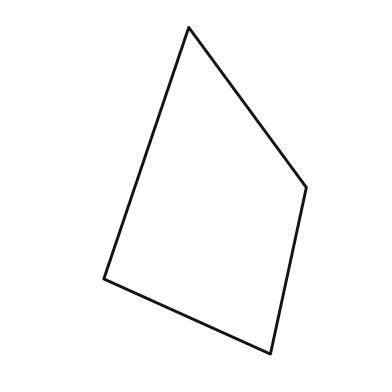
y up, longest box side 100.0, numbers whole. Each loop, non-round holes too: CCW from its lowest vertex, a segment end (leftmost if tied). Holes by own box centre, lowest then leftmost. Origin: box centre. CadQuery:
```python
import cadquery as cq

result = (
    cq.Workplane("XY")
    .moveTo(20.0, -50.0)
    .lineTo(31.0, 1.0)
    .lineTo(-5.0, 50.0)
    .lineTo(-31.0, -27.0)
    .close()
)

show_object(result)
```